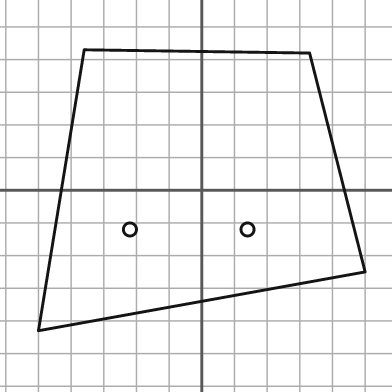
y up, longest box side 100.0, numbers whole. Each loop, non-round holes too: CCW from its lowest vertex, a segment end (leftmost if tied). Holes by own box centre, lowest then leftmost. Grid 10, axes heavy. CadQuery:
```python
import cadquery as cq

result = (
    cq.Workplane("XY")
    .moveTo(-50.0, -43.0)
    .lineTo(50.0, -25.0)
    .lineTo(33.0, 42.0)
    .lineTo(-36.0, 43.0)
    .close()
    .moveTo(-22.0, -12.0)
    .circle(2.0)
    .moveTo(14.0, -12.0)
    .circle(2.0)
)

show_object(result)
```